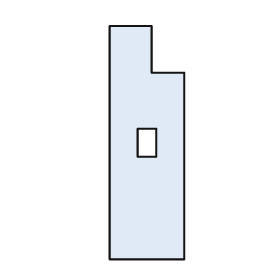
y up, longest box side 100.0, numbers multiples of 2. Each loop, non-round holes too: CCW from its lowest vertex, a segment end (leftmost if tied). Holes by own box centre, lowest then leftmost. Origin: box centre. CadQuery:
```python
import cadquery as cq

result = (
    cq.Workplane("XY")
    .moveTo(-16.0, -50.0)
    .lineTo(16.0, -50.0)
    .lineTo(16.0, 30.0)
    .lineTo(2.0, 30.0)
    .lineTo(2.0, 50.0)
    .lineTo(-16.0, 50.0)
    .close()
    .moveTo(-4.0, -6.0)
    .lineTo(4.0, -6.0)
    .lineTo(4.0, 6.0)
    .lineTo(-4.0, 6.0)
    .close()
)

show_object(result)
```